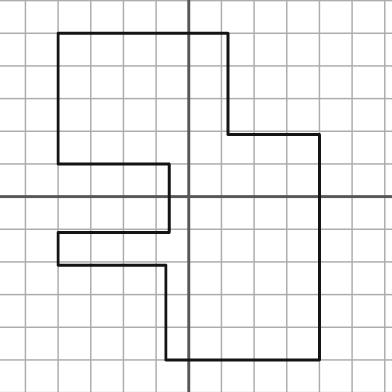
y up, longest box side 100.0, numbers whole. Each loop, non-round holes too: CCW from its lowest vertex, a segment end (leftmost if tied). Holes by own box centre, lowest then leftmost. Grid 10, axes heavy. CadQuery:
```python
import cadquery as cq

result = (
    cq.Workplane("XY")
    .moveTo(-7.0, -50.0)
    .lineTo(40.0, -50.0)
    .lineTo(40.0, 19.0)
    .lineTo(12.0, 19.0)
    .lineTo(12.0, 50.0)
    .lineTo(-40.0, 50.0)
    .lineTo(-40.0, 10.0)
    .lineTo(-6.0, 10.0)
    .lineTo(-6.0, -11.0)
    .lineTo(-40.0, -11.0)
    .lineTo(-40.0, -21.0)
    .lineTo(-7.0, -21.0)
    .close()
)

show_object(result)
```